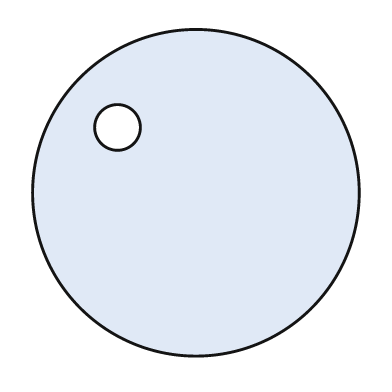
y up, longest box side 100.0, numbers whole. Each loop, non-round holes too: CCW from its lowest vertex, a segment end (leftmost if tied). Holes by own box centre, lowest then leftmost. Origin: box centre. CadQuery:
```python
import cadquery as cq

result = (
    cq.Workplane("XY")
    .moveTo(0.0, 0.0)
    .circle(50.0)
    .moveTo(-24.0, 20.0)
    .circle(7.0)
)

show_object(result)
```